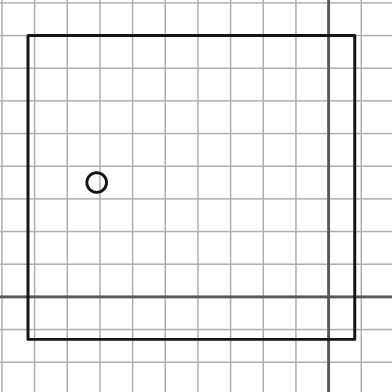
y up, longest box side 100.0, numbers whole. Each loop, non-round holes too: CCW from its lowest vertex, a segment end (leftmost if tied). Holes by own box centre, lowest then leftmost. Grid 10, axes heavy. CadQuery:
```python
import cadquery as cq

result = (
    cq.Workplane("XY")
    .moveTo(-92.0, -13.0)
    .lineTo(8.0, -13.0)
    .lineTo(8.0, 80.0)
    .lineTo(-92.0, 80.0)
    .close()
    .moveTo(-71.0, 35.0)
    .circle(3.0)
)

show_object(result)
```